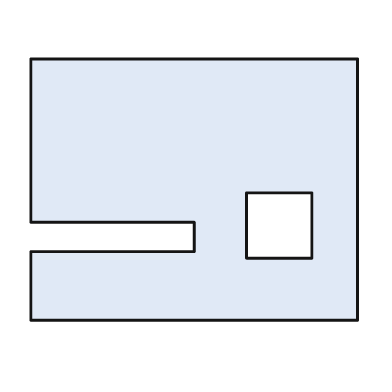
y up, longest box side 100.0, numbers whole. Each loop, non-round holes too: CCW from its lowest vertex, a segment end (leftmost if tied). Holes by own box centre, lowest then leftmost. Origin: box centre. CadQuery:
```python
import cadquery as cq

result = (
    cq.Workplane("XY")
    .moveTo(-50.0, -40.0)
    .lineTo(50.0, -40.0)
    .lineTo(50.0, 40.0)
    .lineTo(-50.0, 40.0)
    .lineTo(-50.0, -10.0)
    .lineTo(0.0, -10.0)
    .lineTo(0.0, -19.0)
    .lineTo(-50.0, -19.0)
    .close()
    .moveTo(16.0, -21.0)
    .lineTo(36.0, -21.0)
    .lineTo(36.0, -1.0)
    .lineTo(16.0, -1.0)
    .close()
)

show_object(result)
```